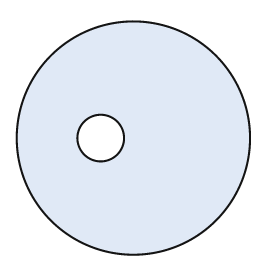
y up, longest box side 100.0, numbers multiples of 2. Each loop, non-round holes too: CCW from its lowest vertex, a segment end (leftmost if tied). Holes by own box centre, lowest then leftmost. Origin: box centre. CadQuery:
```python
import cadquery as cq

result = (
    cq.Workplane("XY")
    .moveTo(0.0, 0.0)
    .circle(50.0)
    .moveTo(-14.0, 0.0)
    .circle(10.0)
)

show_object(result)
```